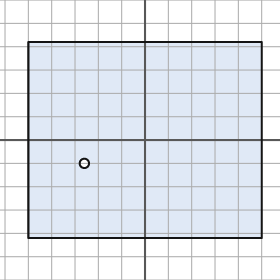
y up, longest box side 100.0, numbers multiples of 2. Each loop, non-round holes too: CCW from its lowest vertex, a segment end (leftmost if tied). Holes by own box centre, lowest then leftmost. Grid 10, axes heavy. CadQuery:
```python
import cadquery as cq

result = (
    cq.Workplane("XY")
    .moveTo(-50.0, -42.0)
    .lineTo(50.0, -42.0)
    .lineTo(50.0, 42.0)
    .lineTo(-50.0, 42.0)
    .close()
    .moveTo(-26.0, -10.0)
    .circle(2.0)
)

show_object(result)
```